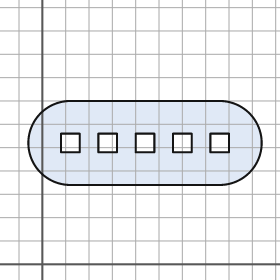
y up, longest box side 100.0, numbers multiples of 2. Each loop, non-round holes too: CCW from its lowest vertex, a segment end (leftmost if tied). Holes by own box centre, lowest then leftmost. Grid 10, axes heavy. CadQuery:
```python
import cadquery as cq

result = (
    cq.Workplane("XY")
    .moveTo(12.0, 34.0)
    .lineTo(76.0, 34.0)
    .threePointArc((94.0, 52.0), (76.0, 70.0))
    .lineTo(12.0, 70.0)
    .threePointArc((-6.0, 52.0), (12.0, 34.0))
    .close()
    .moveTo(8.0, 48.0)
    .lineTo(16.0, 48.0)
    .lineTo(16.0, 56.0)
    .lineTo(8.0, 56.0)
    .close()
    .moveTo(24.0, 48.0)
    .lineTo(32.0, 48.0)
    .lineTo(32.0, 56.0)
    .lineTo(24.0, 56.0)
    .close()
    .moveTo(40.0, 48.0)
    .lineTo(48.0, 48.0)
    .lineTo(48.0, 56.0)
    .lineTo(40.0, 56.0)
    .close()
    .moveTo(56.0, 48.0)
    .lineTo(64.0, 48.0)
    .lineTo(64.0, 56.0)
    .lineTo(56.0, 56.0)
    .close()
    .moveTo(72.0, 48.0)
    .lineTo(80.0, 48.0)
    .lineTo(80.0, 56.0)
    .lineTo(72.0, 56.0)
    .close()
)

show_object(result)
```